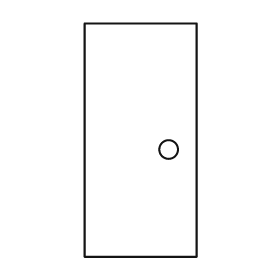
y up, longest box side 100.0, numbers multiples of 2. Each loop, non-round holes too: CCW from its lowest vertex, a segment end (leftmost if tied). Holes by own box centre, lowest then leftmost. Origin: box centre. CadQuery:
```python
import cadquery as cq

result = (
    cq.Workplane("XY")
    .moveTo(-24.0, -50.0)
    .lineTo(24.0, -50.0)
    .lineTo(24.0, 50.0)
    .lineTo(-24.0, 50.0)
    .close()
    .moveTo(12.0, -4.0)
    .circle(4.0)
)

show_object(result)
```